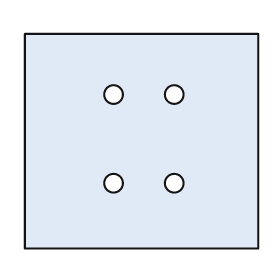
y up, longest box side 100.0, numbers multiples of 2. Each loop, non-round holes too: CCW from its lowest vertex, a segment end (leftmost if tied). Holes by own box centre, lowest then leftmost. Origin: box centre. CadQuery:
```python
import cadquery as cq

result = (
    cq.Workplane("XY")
    .moveTo(-50.0, -46.0)
    .lineTo(50.0, -46.0)
    .lineTo(50.0, 46.0)
    .lineTo(-50.0, 46.0)
    .close()
    .moveTo(-12.0, -18.0)
    .circle(4.0)
    .moveTo(14.0, -18.0)
    .circle(4.0)
    .moveTo(-12.0, 20.0)
    .circle(4.0)
    .moveTo(14.0, 20.0)
    .circle(4.0)
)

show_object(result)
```